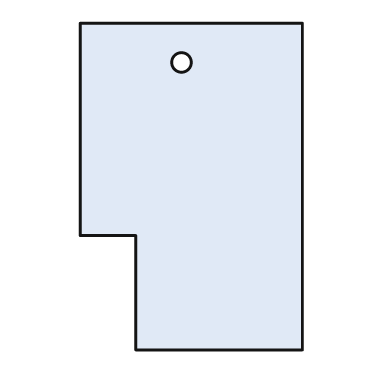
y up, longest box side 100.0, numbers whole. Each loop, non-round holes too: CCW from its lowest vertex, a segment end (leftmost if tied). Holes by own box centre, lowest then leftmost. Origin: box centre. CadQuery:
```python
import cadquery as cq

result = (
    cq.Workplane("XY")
    .moveTo(-17.0, -50.0)
    .lineTo(34.0, -50.0)
    .lineTo(34.0, 50.0)
    .lineTo(-34.0, 50.0)
    .lineTo(-34.0, -15.0)
    .lineTo(-17.0, -15.0)
    .close()
    .moveTo(-3.0, 38.0)
    .circle(3.0)
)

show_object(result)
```